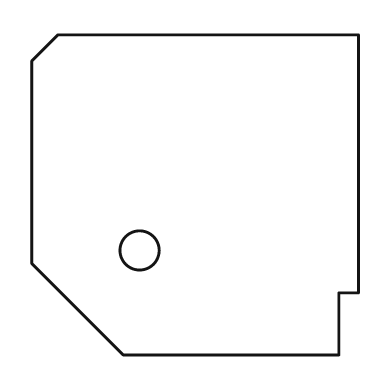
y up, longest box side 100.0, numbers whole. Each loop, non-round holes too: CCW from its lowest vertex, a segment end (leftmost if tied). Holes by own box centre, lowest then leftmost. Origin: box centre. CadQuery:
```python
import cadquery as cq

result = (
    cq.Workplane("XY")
    .moveTo(-22.0, -49.0)
    .lineTo(44.0, -49.0)
    .lineTo(44.0, -30.0)
    .lineTo(50.0, -30.0)
    .lineTo(50.0, 49.0)
    .lineTo(-42.0, 49.0)
    .lineTo(-50.0, 41.0)
    .lineTo(-50.0, -21.0)
    .close()
    .moveTo(-17.0, -17.0)
    .circle(6.0)
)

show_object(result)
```